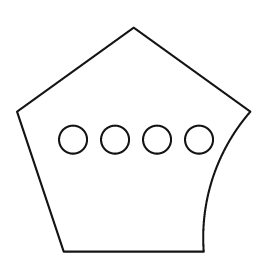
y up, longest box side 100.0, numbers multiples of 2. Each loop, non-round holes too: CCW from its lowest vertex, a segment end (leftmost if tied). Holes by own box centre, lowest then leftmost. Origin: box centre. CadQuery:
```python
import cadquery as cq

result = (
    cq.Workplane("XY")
    .moveTo(-30.0, -48.0)
    .lineTo(30.0, -48.0)
    .threePointArc((34.0, -16.0), (50.0, 12.0))
    .lineTo(0.0, 48.0)
    .lineTo(-50.0, 12.0)
    .close()
    .moveTo(-26.0, 0.0)
    .circle(6.0)
    .moveTo(-8.0, 0.0)
    .circle(6.0)
    .moveTo(10.0, 0.0)
    .circle(6.0)
    .moveTo(28.0, 0.0)
    .circle(6.0)
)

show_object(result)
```